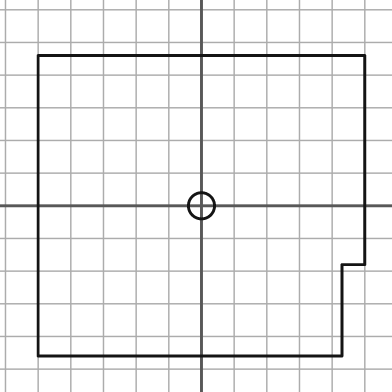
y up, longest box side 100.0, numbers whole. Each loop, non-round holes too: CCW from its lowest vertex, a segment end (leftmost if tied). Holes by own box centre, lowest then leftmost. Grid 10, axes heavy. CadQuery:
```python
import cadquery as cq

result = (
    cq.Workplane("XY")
    .moveTo(-50.0, -46.0)
    .lineTo(43.0, -46.0)
    .lineTo(43.0, -18.0)
    .lineTo(50.0, -18.0)
    .lineTo(50.0, 46.0)
    .lineTo(-50.0, 46.0)
    .close()
    .moveTo(0.0, 0.0)
    .circle(4.0)
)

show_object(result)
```